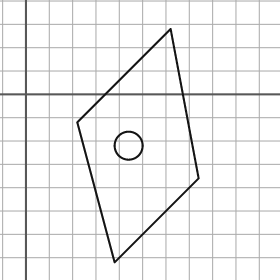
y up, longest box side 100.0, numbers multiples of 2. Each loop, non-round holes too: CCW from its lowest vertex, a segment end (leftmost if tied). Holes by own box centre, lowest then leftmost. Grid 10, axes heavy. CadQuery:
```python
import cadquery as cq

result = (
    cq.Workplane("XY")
    .moveTo(38.0, -72.0)
    .lineTo(74.0, -36.0)
    .lineTo(62.0, 28.0)
    .lineTo(22.0, -12.0)
    .close()
    .moveTo(44.0, -22.0)
    .circle(6.0)
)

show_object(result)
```